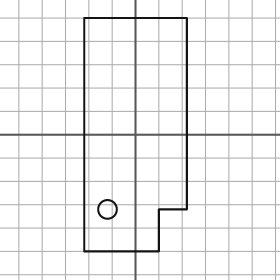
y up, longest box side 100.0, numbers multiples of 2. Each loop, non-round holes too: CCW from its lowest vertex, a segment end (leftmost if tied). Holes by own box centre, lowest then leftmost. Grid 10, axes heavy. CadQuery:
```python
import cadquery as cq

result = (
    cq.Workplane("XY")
    .moveTo(-22.0, -50.0)
    .lineTo(10.0, -50.0)
    .lineTo(10.0, -32.0)
    .lineTo(22.0, -32.0)
    .lineTo(22.0, 50.0)
    .lineTo(-22.0, 50.0)
    .close()
    .moveTo(-12.0, -32.0)
    .circle(4.0)
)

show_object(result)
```